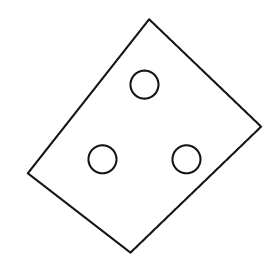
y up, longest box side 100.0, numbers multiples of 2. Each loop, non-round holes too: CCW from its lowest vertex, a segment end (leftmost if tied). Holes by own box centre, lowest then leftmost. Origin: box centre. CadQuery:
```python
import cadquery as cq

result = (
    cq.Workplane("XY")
    .moveTo(-6.0, -50.0)
    .lineTo(50.0, 4.0)
    .lineTo(2.0, 50.0)
    .lineTo(-50.0, -16.0)
    .close()
    .moveTo(-18.0, -10.0)
    .circle(6.0)
    .moveTo(18.0, -10.0)
    .circle(6.0)
    .moveTo(0.0, 22.0)
    .circle(6.0)
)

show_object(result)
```